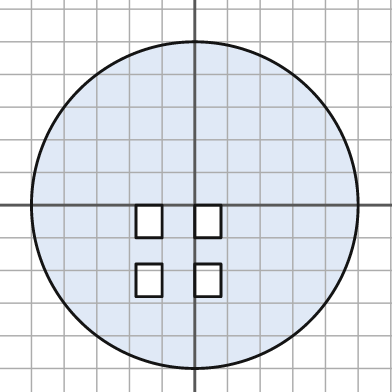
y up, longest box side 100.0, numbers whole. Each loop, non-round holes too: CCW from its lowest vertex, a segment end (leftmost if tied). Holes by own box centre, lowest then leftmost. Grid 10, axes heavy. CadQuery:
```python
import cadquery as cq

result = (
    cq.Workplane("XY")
    .moveTo(0.0, 0.0)
    .circle(50.0)
    .moveTo(-18.0, -28.0)
    .lineTo(-10.0, -28.0)
    .lineTo(-10.0, -18.0)
    .lineTo(-18.0, -18.0)
    .close()
    .moveTo(0.0, -28.0)
    .lineTo(8.0, -28.0)
    .lineTo(8.0, -18.0)
    .lineTo(0.0, -18.0)
    .close()
    .moveTo(-18.0, -10.0)
    .lineTo(-10.0, -10.0)
    .lineTo(-10.0, 0.0)
    .lineTo(-18.0, 0.0)
    .close()
    .moveTo(0.0, -10.0)
    .lineTo(8.0, -10.0)
    .lineTo(8.0, 0.0)
    .lineTo(0.0, 0.0)
    .close()
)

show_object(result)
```